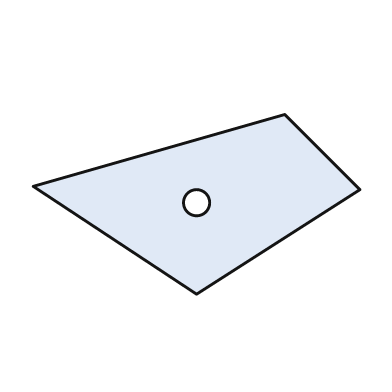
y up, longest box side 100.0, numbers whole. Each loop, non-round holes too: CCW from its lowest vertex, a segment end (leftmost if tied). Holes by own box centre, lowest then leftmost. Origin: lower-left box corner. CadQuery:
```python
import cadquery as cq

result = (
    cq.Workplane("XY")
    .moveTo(50.0, 0.0)
    .lineTo(100.0, 32.0)
    .lineTo(77.0, 55.0)
    .lineTo(0.0, 33.0)
    .close()
    .moveTo(50.0, 28.0)
    .circle(4.0)
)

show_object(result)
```